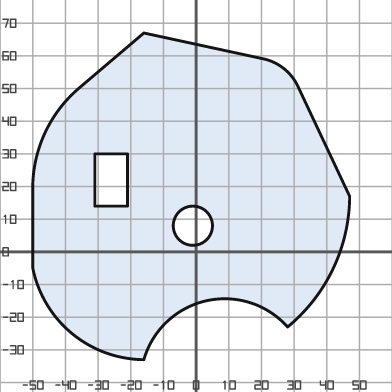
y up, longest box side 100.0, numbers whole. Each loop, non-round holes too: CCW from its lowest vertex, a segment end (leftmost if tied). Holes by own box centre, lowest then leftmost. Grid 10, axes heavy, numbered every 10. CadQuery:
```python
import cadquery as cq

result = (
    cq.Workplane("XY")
    .moveTo(-16.0, -33.0)
    .threePointArc((3.0, -15.0), (28.0, -23.0))
    .threePointArc((42.0, -5.0), (47.0, 17.0))
    .lineTo(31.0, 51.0)
    .threePointArc((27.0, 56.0), (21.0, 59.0))
    .lineTo(-16.0, 67.0)
    .lineTo(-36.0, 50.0)
    .threePointArc((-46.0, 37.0), (-50.0, 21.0))
    .lineTo(-50.0, -5.0)
    .threePointArc((-38.0, -25.0), (-16.0, -33.0))
    .close()
    .moveTo(-1.0, 8.0)
    .circle(6.0)
    .moveTo(-31.0, 14.0)
    .lineTo(-21.0, 14.0)
    .lineTo(-21.0, 30.0)
    .lineTo(-31.0, 30.0)
    .close()
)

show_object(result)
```